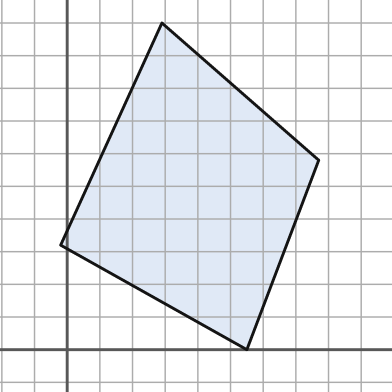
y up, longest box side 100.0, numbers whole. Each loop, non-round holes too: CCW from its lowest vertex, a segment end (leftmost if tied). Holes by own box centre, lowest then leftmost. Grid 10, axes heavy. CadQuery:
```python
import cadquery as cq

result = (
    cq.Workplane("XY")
    .moveTo(55.0, 0.0)
    .lineTo(77.0, 58.0)
    .lineTo(29.0, 100.0)
    .lineTo(-2.0, 32.0)
    .close()
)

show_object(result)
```